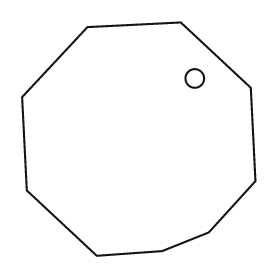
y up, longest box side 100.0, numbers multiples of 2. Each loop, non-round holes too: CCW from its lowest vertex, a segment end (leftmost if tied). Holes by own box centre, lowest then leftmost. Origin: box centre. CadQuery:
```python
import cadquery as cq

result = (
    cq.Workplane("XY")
    .moveTo(-18.0, -50.0)
    .lineTo(10.0, -48.0)
    .lineTo(30.0, -40.0)
    .lineTo(50.0, -18.0)
    .lineTo(48.0, 22.0)
    .lineTo(18.0, 50.0)
    .lineTo(-22.0, 48.0)
    .lineTo(-50.0, 18.0)
    .lineTo(-48.0, -22.0)
    .close()
    .moveTo(24.0, 26.0)
    .circle(4.0)
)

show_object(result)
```